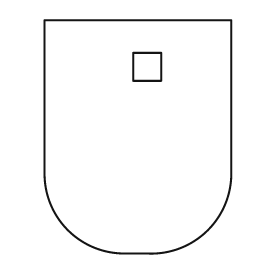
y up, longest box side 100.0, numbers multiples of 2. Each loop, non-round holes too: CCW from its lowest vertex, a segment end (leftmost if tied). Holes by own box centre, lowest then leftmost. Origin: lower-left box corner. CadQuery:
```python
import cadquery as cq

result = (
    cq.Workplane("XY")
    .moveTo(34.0, 0.0)
    .lineTo(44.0, 0.0)
    .threePointArc((70.0, 10.0), (80.0, 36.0))
    .lineTo(80.0, 100.0)
    .lineTo(0.0, 100.0)
    .lineTo(0.0, 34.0)
    .threePointArc((10.0, 10.0), (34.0, 0.0))
    .close()
    .moveTo(38.0, 74.0)
    .lineTo(50.0, 74.0)
    .lineTo(50.0, 86.0)
    .lineTo(38.0, 86.0)
    .close()
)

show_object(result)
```